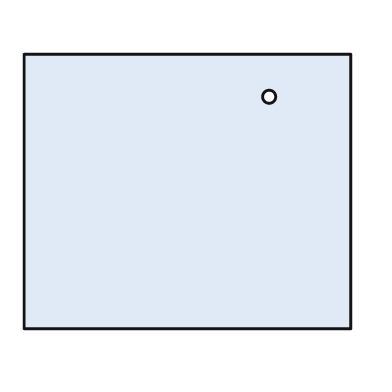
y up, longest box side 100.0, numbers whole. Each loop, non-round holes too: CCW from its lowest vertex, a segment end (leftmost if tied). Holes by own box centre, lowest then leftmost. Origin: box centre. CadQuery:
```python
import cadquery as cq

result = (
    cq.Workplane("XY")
    .moveTo(-50.0, -42.0)
    .lineTo(50.0, -42.0)
    .lineTo(50.0, 42.0)
    .lineTo(-50.0, 42.0)
    .close()
    .moveTo(25.0, 29.0)
    .circle(2.0)
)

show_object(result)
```